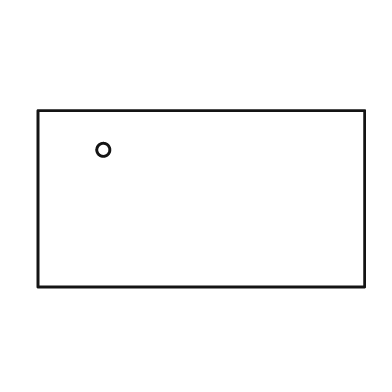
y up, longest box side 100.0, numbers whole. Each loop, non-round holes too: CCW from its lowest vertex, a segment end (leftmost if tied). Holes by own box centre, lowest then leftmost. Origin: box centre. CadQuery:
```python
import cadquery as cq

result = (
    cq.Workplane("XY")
    .moveTo(-50.0, -27.0)
    .lineTo(50.0, -27.0)
    .lineTo(50.0, 27.0)
    .lineTo(-50.0, 27.0)
    .close()
    .moveTo(-30.0, 15.0)
    .circle(2.0)
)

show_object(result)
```